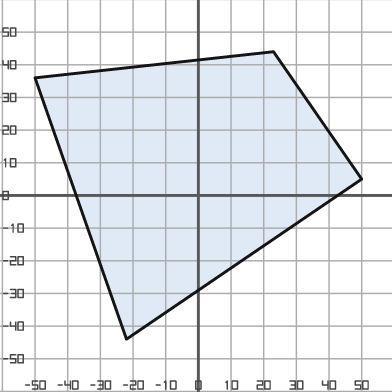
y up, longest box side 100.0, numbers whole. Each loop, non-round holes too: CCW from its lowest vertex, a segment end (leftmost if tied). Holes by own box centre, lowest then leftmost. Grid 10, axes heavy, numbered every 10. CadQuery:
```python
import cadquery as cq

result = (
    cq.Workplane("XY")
    .moveTo(-22.0, -44.0)
    .lineTo(50.0, 5.0)
    .lineTo(23.0, 44.0)
    .lineTo(-50.0, 36.0)
    .close()
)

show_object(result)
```